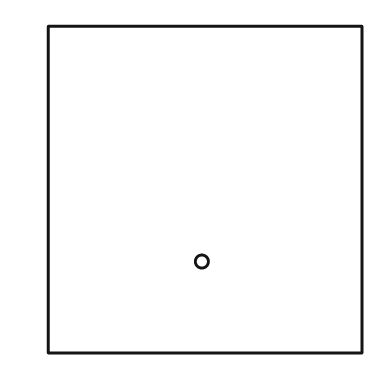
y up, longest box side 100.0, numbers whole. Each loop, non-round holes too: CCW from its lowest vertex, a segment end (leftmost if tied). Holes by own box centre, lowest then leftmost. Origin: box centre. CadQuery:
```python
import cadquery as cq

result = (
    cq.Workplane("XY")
    .moveTo(-48.0, -50.0)
    .lineTo(48.0, -50.0)
    .lineTo(48.0, 50.0)
    .lineTo(-48.0, 50.0)
    .close()
    .moveTo(-1.0, -22.0)
    .circle(2.0)
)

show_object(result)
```